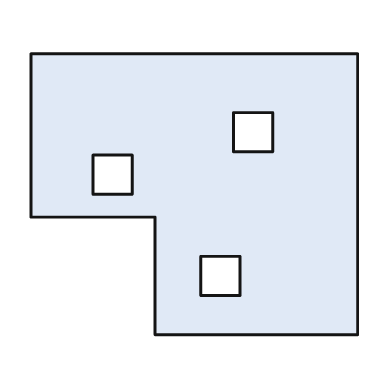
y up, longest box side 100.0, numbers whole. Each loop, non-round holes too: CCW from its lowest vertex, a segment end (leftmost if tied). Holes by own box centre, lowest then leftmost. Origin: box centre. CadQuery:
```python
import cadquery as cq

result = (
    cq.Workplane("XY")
    .moveTo(-12.0, -43.0)
    .lineTo(50.0, -43.0)
    .lineTo(50.0, 43.0)
    .lineTo(-50.0, 43.0)
    .lineTo(-50.0, -7.0)
    .lineTo(-12.0, -7.0)
    .close()
    .moveTo(2.0, -31.0)
    .lineTo(14.0, -31.0)
    .lineTo(14.0, -19.0)
    .lineTo(2.0, -19.0)
    .close()
    .moveTo(-31.0, 0.0)
    .lineTo(-19.0, 0.0)
    .lineTo(-19.0, 12.0)
    .lineTo(-31.0, 12.0)
    .close()
    .moveTo(12.0, 13.0)
    .lineTo(24.0, 13.0)
    .lineTo(24.0, 25.0)
    .lineTo(12.0, 25.0)
    .close()
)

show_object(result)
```